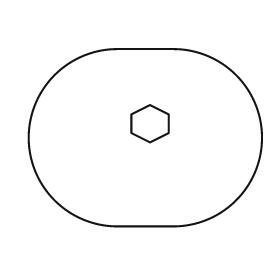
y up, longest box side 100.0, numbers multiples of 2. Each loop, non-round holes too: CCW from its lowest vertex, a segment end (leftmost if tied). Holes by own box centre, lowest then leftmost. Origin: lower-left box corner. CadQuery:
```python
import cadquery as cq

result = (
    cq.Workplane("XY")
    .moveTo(38.0, 0.0)
    .lineTo(62.0, 0.0)
    .threePointArc((100.0, 38.0), (62.0, 76.0))
    .lineTo(38.0, 76.0)
    .threePointArc((0.0, 38.0), (38.0, 0.0))
    .close()
    .moveTo(52.0, 36.0)
    .lineTo(60.0, 40.0)
    .lineTo(60.0, 48.0)
    .lineTo(52.0, 52.0)
    .lineTo(44.0, 48.0)
    .lineTo(44.0, 40.0)
    .close()
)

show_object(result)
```